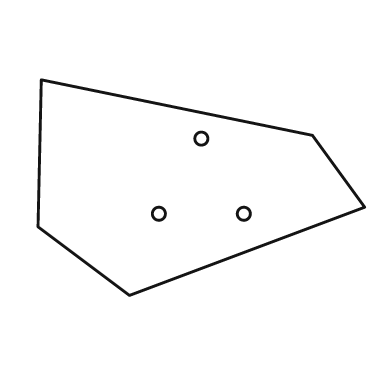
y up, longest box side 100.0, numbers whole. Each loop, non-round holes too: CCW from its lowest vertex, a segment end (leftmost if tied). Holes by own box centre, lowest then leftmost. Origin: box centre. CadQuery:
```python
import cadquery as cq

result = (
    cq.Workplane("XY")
    .moveTo(-22.0, -33.0)
    .lineTo(50.0, -6.0)
    .lineTo(34.0, 16.0)
    .lineTo(-49.0, 33.0)
    .lineTo(-50.0, -12.0)
    .close()
    .moveTo(-13.0, -8.0)
    .circle(2.0)
    .moveTo(13.0, -8.0)
    .circle(2.0)
    .moveTo(0.0, 15.0)
    .circle(2.0)
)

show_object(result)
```